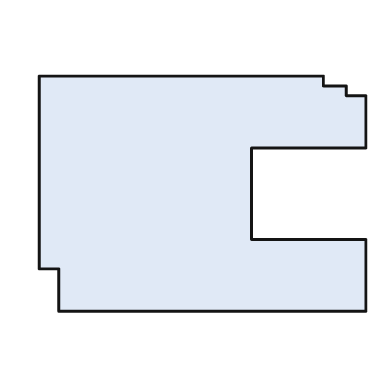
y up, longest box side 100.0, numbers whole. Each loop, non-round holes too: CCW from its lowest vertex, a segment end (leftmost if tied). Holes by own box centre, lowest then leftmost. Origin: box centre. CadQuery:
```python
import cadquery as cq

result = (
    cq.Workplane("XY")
    .moveTo(-44.0, -36.0)
    .lineTo(50.0, -36.0)
    .lineTo(50.0, -14.0)
    .lineTo(15.0, -14.0)
    .lineTo(15.0, 14.0)
    .lineTo(50.0, 14.0)
    .lineTo(50.0, 30.0)
    .lineTo(44.0, 30.0)
    .lineTo(44.0, 33.0)
    .lineTo(37.0, 33.0)
    .lineTo(37.0, 36.0)
    .lineTo(-50.0, 36.0)
    .lineTo(-50.0, -23.0)
    .lineTo(-44.0, -23.0)
    .close()
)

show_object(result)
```